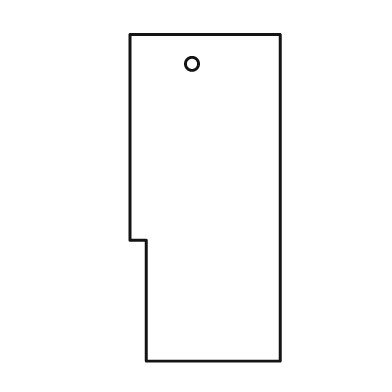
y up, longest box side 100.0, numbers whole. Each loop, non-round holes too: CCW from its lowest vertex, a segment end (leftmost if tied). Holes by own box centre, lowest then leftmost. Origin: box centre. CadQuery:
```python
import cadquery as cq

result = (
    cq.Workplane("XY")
    .moveTo(-18.0, -50.0)
    .lineTo(23.0, -50.0)
    .lineTo(23.0, 50.0)
    .lineTo(-23.0, 50.0)
    .lineTo(-23.0, -13.0)
    .lineTo(-18.0, -13.0)
    .close()
    .moveTo(-4.0, 41.0)
    .circle(2.0)
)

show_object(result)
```